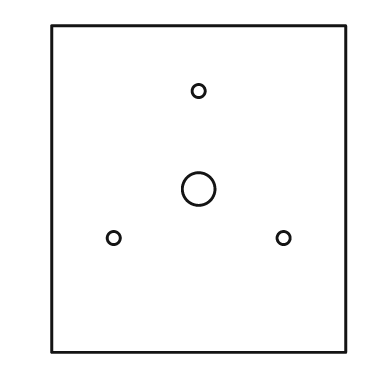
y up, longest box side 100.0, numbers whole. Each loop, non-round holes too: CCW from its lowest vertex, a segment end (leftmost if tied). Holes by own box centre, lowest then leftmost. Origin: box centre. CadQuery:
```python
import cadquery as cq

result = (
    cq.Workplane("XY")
    .moveTo(-45.0, -50.0)
    .lineTo(45.0, -50.0)
    .lineTo(45.0, 50.0)
    .lineTo(-45.0, 50.0)
    .close()
    .moveTo(-26.0, -15.0)
    .circle(2.0)
    .moveTo(26.0, -15.0)
    .circle(2.0)
    .moveTo(0.0, 0.0)
    .circle(5.0)
    .moveTo(0.0, 30.0)
    .circle(2.0)
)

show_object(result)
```